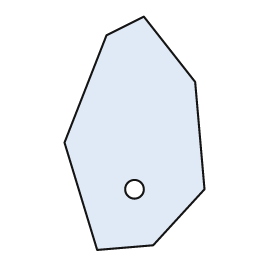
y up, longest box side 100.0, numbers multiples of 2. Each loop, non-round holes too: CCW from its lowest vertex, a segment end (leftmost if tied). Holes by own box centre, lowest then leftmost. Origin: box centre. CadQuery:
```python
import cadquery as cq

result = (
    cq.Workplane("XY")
    .moveTo(-16.0, -50.0)
    .lineTo(8.0, -48.0)
    .lineTo(30.0, -24.0)
    .lineTo(26.0, 22.0)
    .lineTo(4.0, 50.0)
    .lineTo(-12.0, 42.0)
    .lineTo(-30.0, -4.0)
    .close()
    .moveTo(0.0, -24.0)
    .circle(4.0)
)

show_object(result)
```